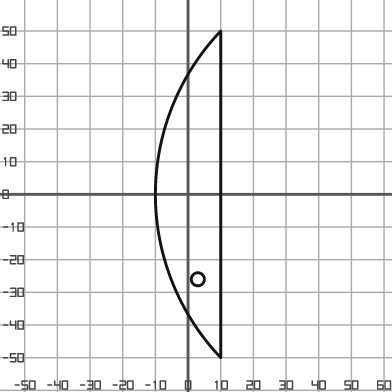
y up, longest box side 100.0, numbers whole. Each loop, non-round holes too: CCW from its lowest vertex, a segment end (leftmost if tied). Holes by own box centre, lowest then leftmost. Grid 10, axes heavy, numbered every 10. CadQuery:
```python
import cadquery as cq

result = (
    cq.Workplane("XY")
    .moveTo(10.0, -50.0)
    .lineTo(10.0, 50.0)
    .threePointArc((-10.0, 0.0), (10.0, -50.0))
    .close()
    .moveTo(3.0, -26.0)
    .circle(2.0)
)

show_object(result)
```